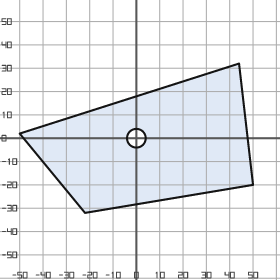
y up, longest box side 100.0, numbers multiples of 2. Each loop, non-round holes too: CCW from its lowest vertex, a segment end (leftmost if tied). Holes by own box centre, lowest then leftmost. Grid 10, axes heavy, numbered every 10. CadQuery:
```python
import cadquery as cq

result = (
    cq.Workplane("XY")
    .moveTo(-22.0, -32.0)
    .lineTo(50.0, -20.0)
    .lineTo(44.0, 32.0)
    .lineTo(-50.0, 2.0)
    .close()
    .moveTo(0.0, 0.0)
    .circle(4.0)
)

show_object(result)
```